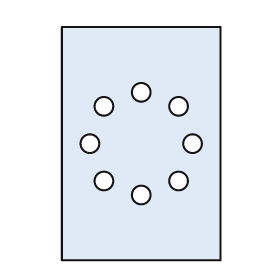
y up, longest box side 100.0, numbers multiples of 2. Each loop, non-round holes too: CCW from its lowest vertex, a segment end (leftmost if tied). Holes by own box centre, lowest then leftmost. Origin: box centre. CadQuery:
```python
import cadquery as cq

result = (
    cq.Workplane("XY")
    .moveTo(-34.0, -50.0)
    .lineTo(34.0, -50.0)
    .lineTo(34.0, 50.0)
    .lineTo(-34.0, 50.0)
    .close()
    .moveTo(0.0, -22.0)
    .circle(4.0)
    .moveTo(-16.0, -16.0)
    .circle(4.0)
    .moveTo(16.0, -16.0)
    .circle(4.0)
    .moveTo(-22.0, 0.0)
    .circle(4.0)
    .moveTo(22.0, 0.0)
    .circle(4.0)
    .moveTo(-16.0, 16.0)
    .circle(4.0)
    .moveTo(16.0, 16.0)
    .circle(4.0)
    .moveTo(0.0, 22.0)
    .circle(4.0)
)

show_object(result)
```